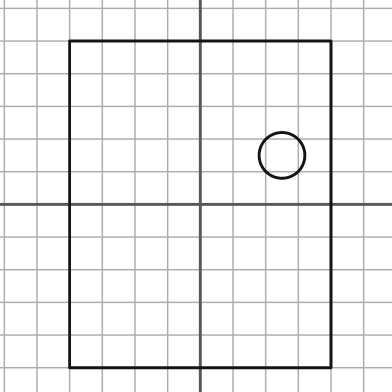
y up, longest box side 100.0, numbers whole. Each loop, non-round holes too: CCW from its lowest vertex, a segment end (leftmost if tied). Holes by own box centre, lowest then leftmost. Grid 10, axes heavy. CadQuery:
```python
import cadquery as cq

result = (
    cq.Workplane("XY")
    .moveTo(-40.0, -50.0)
    .lineTo(40.0, -50.0)
    .lineTo(40.0, 50.0)
    .lineTo(-40.0, 50.0)
    .close()
    .moveTo(25.0, 15.0)
    .circle(7.0)
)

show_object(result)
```